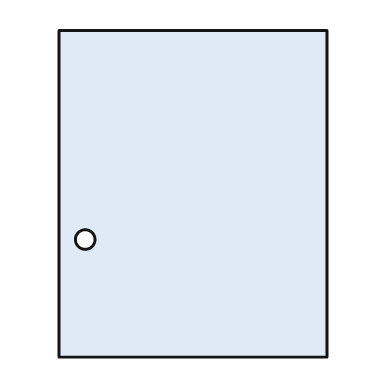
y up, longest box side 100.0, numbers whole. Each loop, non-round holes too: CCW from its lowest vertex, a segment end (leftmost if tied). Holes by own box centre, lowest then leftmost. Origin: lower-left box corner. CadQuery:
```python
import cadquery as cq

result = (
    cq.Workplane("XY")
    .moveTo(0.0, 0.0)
    .lineTo(82.0, 0.0)
    .lineTo(82.0, 100.0)
    .lineTo(0.0, 100.0)
    .close()
    .moveTo(8.0, 36.0)
    .circle(3.0)
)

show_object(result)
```